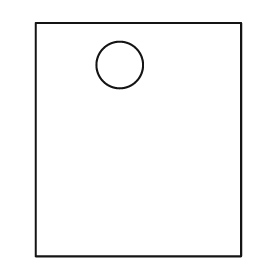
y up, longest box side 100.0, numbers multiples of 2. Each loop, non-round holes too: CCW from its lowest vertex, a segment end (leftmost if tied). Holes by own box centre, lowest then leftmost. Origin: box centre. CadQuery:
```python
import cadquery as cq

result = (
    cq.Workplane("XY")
    .moveTo(-44.0, -50.0)
    .lineTo(44.0, -50.0)
    .lineTo(44.0, 50.0)
    .lineTo(-44.0, 50.0)
    .close()
    .moveTo(-8.0, 32.0)
    .circle(10.0)
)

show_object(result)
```